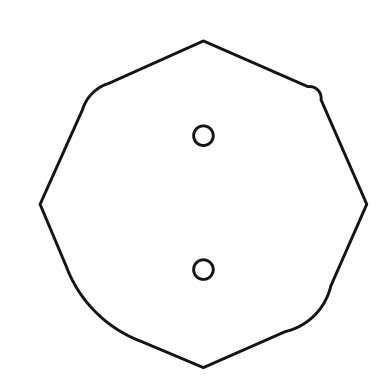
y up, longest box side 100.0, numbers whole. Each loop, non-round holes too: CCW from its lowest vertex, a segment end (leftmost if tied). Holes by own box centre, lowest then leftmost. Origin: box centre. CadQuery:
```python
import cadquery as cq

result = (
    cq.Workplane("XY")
    .moveTo(0.0, -50.0)
    .lineTo(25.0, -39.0)
    .threePointArc((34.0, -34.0), (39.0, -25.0))
    .lineTo(50.0, 0.0)
    .lineTo(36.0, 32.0)
    .threePointArc((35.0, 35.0), (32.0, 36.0))
    .lineTo(0.0, 50.0)
    .lineTo(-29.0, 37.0)
    .threePointArc((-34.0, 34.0), (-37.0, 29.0))
    .lineTo(-50.0, 0.0)
    .lineTo(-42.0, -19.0)
    .threePointArc((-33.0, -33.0), (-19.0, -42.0))
    .close()
    .moveTo(0.0, -20.0)
    .circle(3.0)
    .moveTo(0.0, 21.0)
    .circle(3.0)
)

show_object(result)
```